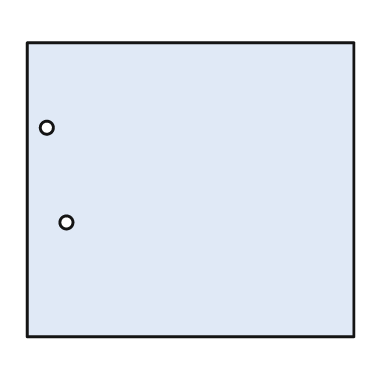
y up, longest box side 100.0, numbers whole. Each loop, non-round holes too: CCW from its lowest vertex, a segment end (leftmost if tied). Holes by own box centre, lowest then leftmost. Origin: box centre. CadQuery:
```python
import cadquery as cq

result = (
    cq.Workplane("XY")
    .moveTo(-50.0, -45.0)
    .lineTo(50.0, -45.0)
    .lineTo(50.0, 45.0)
    .lineTo(-50.0, 45.0)
    .close()
    .moveTo(-38.0, -10.0)
    .circle(2.0)
    .moveTo(-44.0, 19.0)
    .circle(2.0)
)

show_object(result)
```